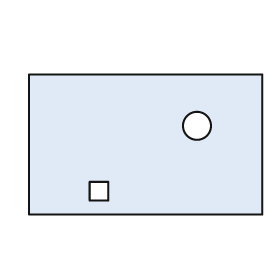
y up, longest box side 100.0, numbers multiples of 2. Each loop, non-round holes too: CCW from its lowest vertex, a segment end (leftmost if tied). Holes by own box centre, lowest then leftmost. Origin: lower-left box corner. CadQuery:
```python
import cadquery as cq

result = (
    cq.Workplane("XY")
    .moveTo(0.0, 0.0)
    .lineTo(100.0, 0.0)
    .lineTo(100.0, 60.0)
    .lineTo(0.0, 60.0)
    .close()
    .moveTo(26.0, 6.0)
    .lineTo(34.0, 6.0)
    .lineTo(34.0, 14.0)
    .lineTo(26.0, 14.0)
    .close()
    .moveTo(72.0, 38.0)
    .circle(6.0)
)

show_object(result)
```